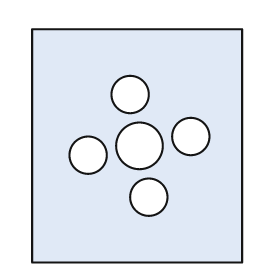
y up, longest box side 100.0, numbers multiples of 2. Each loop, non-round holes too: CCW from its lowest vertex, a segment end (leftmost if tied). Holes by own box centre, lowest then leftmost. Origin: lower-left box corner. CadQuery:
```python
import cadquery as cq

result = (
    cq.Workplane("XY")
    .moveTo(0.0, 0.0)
    .lineTo(90.0, 0.0)
    .lineTo(90.0, 100.0)
    .lineTo(0.0, 100.0)
    .close()
    .moveTo(50.0, 28.0)
    .circle(8.0)
    .moveTo(24.0, 46.0)
    .circle(8.0)
    .moveTo(46.0, 50.0)
    .circle(10.0)
    .moveTo(68.0, 54.0)
    .circle(8.0)
    .moveTo(42.0, 72.0)
    .circle(8.0)
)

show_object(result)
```